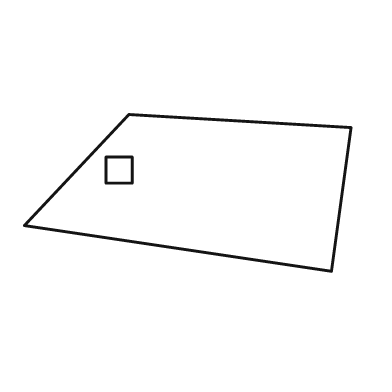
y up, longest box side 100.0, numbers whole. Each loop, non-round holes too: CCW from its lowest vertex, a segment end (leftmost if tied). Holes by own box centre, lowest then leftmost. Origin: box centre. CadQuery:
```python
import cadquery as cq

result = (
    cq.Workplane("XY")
    .moveTo(44.0, -24.0)
    .lineTo(50.0, 20.0)
    .lineTo(-18.0, 24.0)
    .lineTo(-50.0, -10.0)
    .close()
    .moveTo(-25.0, 3.0)
    .lineTo(-17.0, 3.0)
    .lineTo(-17.0, 11.0)
    .lineTo(-25.0, 11.0)
    .close()
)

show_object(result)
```